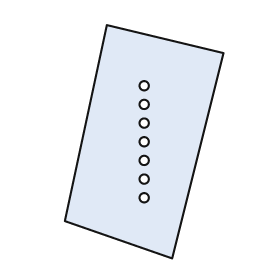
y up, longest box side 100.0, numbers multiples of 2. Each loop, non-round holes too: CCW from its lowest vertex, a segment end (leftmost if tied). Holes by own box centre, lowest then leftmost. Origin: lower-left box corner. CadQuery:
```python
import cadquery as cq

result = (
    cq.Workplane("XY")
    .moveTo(46.0, 0.0)
    .lineTo(68.0, 88.0)
    .lineTo(18.0, 100.0)
    .lineTo(0.0, 16.0)
    .close()
    .moveTo(34.0, 26.0)
    .circle(2.0)
    .moveTo(34.0, 34.0)
    .circle(2.0)
    .moveTo(34.0, 42.0)
    .circle(2.0)
    .moveTo(34.0, 50.0)
    .circle(2.0)
    .moveTo(34.0, 58.0)
    .circle(2.0)
    .moveTo(34.0, 66.0)
    .circle(2.0)
    .moveTo(34.0, 74.0)
    .circle(2.0)
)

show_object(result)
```